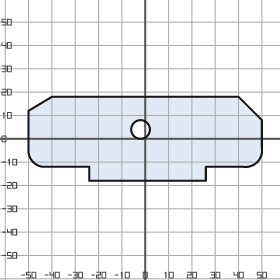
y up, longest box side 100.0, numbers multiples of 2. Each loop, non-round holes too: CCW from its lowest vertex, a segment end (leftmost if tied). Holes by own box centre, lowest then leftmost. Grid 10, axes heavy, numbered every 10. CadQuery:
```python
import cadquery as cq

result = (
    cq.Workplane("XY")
    .moveTo(-24.0, -18.0)
    .lineTo(26.0, -18.0)
    .lineTo(26.0, -12.0)
    .lineTo(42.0, -12.0)
    .threePointArc((48.0, -10.0), (50.0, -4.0))
    .lineTo(50.0, 8.0)
    .lineTo(40.0, 18.0)
    .lineTo(-40.0, 18.0)
    .lineTo(-50.0, 12.0)
    .lineTo(-50.0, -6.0)
    .threePointArc((-48.0, -10.0), (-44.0, -12.0))
    .lineTo(-24.0, -12.0)
    .close()
    .moveTo(-2.0, 4.0)
    .circle(4.0)
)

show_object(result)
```